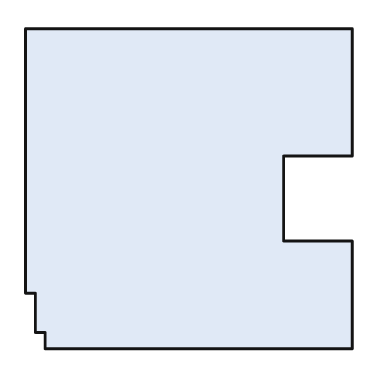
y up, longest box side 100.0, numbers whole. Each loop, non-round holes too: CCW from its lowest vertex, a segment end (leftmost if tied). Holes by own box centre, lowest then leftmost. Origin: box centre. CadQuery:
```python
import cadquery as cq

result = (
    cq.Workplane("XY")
    .moveTo(-44.0, -49.0)
    .lineTo(50.0, -49.0)
    .lineTo(50.0, -16.0)
    .lineTo(29.0, -16.0)
    .lineTo(29.0, 10.0)
    .lineTo(50.0, 10.0)
    .lineTo(50.0, 49.0)
    .lineTo(-50.0, 49.0)
    .lineTo(-50.0, -32.0)
    .lineTo(-47.0, -32.0)
    .lineTo(-47.0, -44.0)
    .lineTo(-44.0, -44.0)
    .close()
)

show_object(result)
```